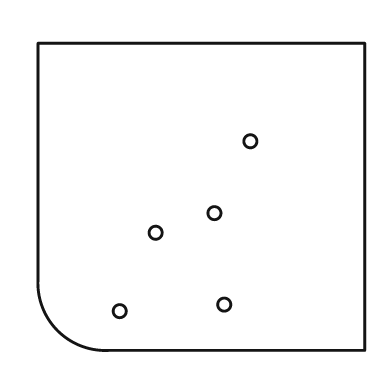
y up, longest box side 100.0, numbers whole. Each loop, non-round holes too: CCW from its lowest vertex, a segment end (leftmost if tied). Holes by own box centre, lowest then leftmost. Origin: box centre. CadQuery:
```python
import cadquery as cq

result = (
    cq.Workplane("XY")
    .moveTo(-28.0, -47.0)
    .lineTo(50.0, -47.0)
    .lineTo(50.0, 47.0)
    .lineTo(-50.0, 47.0)
    .lineTo(-50.0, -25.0)
    .threePointArc((-44.0, -41.0), (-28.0, -47.0))
    .close()
    .moveTo(-25.0, -35.0)
    .circle(2.0)
    .moveTo(7.0, -33.0)
    .circle(2.0)
    .moveTo(-14.0, -11.0)
    .circle(2.0)
    .moveTo(4.0, -5.0)
    .circle(2.0)
    .moveTo(15.0, 17.0)
    .circle(2.0)
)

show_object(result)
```